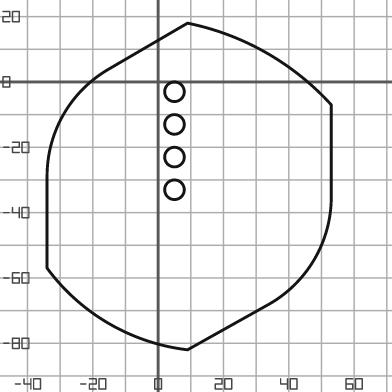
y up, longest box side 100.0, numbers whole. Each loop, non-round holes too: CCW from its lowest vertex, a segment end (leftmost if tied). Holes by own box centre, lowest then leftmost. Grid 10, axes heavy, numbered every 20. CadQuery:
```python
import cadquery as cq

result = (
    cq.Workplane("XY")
    .moveTo(9.0, -82.0)
    .lineTo(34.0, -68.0)
    .threePointArc((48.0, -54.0), (53.0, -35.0))
    .lineTo(53.0, -7.0)
    .threePointArc((33.0, 9.0), (9.0, 18.0))
    .lineTo(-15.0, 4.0)
    .threePointArc((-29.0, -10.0), (-34.0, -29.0))
    .lineTo(-34.0, -57.0)
    .threePointArc((-15.0, -74.0), (9.0, -82.0))
    .close()
    .moveTo(5.0, -33.0)
    .circle(3.0)
    .moveTo(5.0, -23.0)
    .circle(3.0)
    .moveTo(5.0, -13.0)
    .circle(3.0)
    .moveTo(5.0, -3.0)
    .circle(3.0)
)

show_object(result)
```